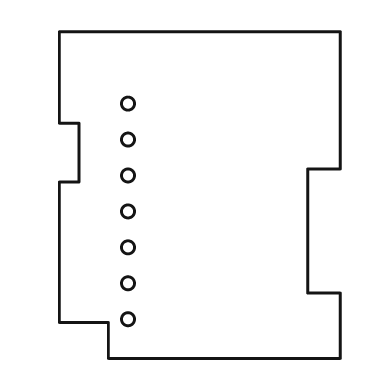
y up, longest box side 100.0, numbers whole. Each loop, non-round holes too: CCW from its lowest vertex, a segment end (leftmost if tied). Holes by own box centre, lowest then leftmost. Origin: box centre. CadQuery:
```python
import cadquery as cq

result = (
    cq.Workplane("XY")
    .moveTo(-28.0, -50.0)
    .lineTo(43.0, -50.0)
    .lineTo(43.0, -30.0)
    .lineTo(33.0, -30.0)
    .lineTo(33.0, 8.0)
    .lineTo(43.0, 8.0)
    .lineTo(43.0, 50.0)
    .lineTo(-43.0, 50.0)
    .lineTo(-43.0, 22.0)
    .lineTo(-37.0, 22.0)
    .lineTo(-37.0, 4.0)
    .lineTo(-43.0, 4.0)
    .lineTo(-43.0, -39.0)
    .lineTo(-28.0, -39.0)
    .close()
    .moveTo(-22.0, -38.0)
    .circle(2.0)
    .moveTo(-22.0, -27.0)
    .circle(2.0)
    .moveTo(-22.0, -16.0)
    .circle(2.0)
    .moveTo(-22.0, -5.0)
    .circle(2.0)
    .moveTo(-22.0, 6.0)
    .circle(2.0)
    .moveTo(-22.0, 17.0)
    .circle(2.0)
    .moveTo(-22.0, 28.0)
    .circle(2.0)
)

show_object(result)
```